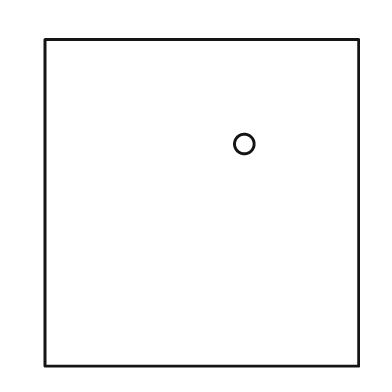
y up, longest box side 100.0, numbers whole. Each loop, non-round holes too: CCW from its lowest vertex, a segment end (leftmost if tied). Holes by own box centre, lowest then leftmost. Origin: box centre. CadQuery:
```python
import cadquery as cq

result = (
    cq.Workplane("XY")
    .moveTo(-48.0, -50.0)
    .lineTo(48.0, -50.0)
    .lineTo(48.0, 50.0)
    .lineTo(-48.0, 50.0)
    .close()
    .moveTo(13.0, 18.0)
    .circle(3.0)
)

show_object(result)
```